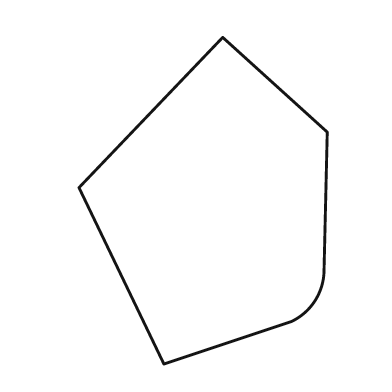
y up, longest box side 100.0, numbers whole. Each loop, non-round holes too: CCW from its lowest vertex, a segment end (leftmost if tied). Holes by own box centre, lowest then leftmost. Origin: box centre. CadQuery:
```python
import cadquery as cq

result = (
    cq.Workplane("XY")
    .moveTo(-12.0, -50.0)
    .lineTo(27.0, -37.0)
    .threePointArc((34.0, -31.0), (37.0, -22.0))
    .lineTo(38.0, 21.0)
    .lineTo(6.0, 50.0)
    .lineTo(-38.0, 4.0)
    .close()
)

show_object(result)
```